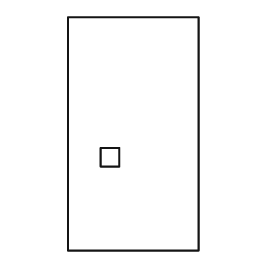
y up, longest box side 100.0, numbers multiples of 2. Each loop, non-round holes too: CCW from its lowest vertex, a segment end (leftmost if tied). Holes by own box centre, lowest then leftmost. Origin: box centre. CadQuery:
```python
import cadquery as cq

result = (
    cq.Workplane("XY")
    .moveTo(-28.0, -50.0)
    .lineTo(28.0, -50.0)
    .lineTo(28.0, 50.0)
    .lineTo(-28.0, 50.0)
    .close()
    .moveTo(-14.0, -14.0)
    .lineTo(-6.0, -14.0)
    .lineTo(-6.0, -6.0)
    .lineTo(-14.0, -6.0)
    .close()
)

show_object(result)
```